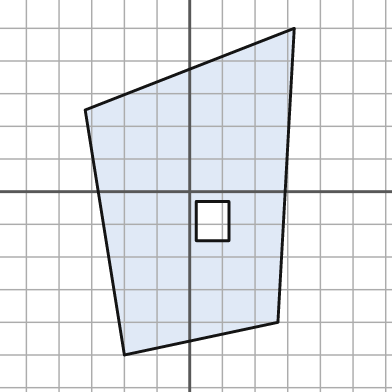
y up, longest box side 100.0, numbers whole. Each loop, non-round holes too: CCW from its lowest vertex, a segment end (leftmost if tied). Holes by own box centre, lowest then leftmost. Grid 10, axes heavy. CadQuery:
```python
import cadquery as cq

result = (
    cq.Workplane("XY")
    .moveTo(-20.0, -50.0)
    .lineTo(27.0, -40.0)
    .lineTo(32.0, 50.0)
    .lineTo(-32.0, 25.0)
    .close()
    .moveTo(2.0, -15.0)
    .lineTo(12.0, -15.0)
    .lineTo(12.0, -3.0)
    .lineTo(2.0, -3.0)
    .close()
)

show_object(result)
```